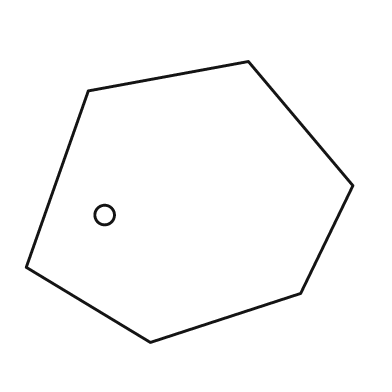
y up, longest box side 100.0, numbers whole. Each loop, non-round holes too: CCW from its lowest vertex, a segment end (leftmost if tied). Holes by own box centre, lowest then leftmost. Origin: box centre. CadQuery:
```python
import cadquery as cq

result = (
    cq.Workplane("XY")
    .moveTo(-12.0, -43.0)
    .lineTo(34.0, -28.0)
    .lineTo(50.0, 5.0)
    .lineTo(18.0, 43.0)
    .lineTo(-31.0, 34.0)
    .lineTo(-50.0, -20.0)
    .close()
    .moveTo(-26.0, -4.0)
    .circle(3.0)
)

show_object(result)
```